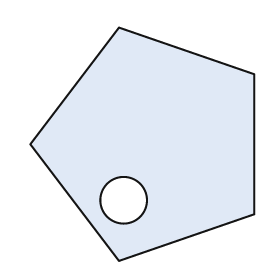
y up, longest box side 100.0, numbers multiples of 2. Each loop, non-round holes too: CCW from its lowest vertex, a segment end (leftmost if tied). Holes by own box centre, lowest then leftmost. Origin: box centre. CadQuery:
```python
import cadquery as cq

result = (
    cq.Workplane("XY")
    .moveTo(-10.0, -50.0)
    .lineTo(48.0, -30.0)
    .lineTo(48.0, 30.0)
    .lineTo(-10.0, 50.0)
    .lineTo(-48.0, 0.0)
    .close()
    .moveTo(-8.0, -24.0)
    .circle(10.0)
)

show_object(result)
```